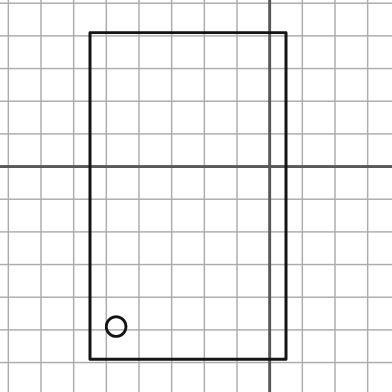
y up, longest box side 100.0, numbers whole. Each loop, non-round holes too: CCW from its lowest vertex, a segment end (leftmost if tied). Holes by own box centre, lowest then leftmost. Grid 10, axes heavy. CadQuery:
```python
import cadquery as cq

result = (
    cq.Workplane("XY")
    .moveTo(-55.0, -59.0)
    .lineTo(5.0, -59.0)
    .lineTo(5.0, 41.0)
    .lineTo(-55.0, 41.0)
    .close()
    .moveTo(-47.0, -49.0)
    .circle(3.0)
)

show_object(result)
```